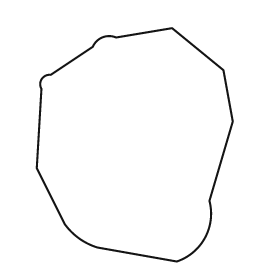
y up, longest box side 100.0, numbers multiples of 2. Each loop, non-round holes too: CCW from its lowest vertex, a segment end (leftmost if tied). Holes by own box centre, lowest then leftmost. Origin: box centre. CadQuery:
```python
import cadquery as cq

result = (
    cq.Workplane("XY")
    .moveTo(18.0, -50.0)
    .threePointArc((30.0, -40.0), (32.0, -24.0))
    .lineTo(42.0, 10.0)
    .lineTo(38.0, 32.0)
    .lineTo(16.0, 50.0)
    .lineTo(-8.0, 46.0)
    .threePointArc((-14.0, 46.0), (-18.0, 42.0))
    .lineTo(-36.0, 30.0)
    .threePointArc((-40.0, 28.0), (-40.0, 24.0))
    .lineTo(-42.0, -10.0)
    .lineTo(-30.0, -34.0)
    .threePointArc((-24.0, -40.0), (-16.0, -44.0))
    .close()
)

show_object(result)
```